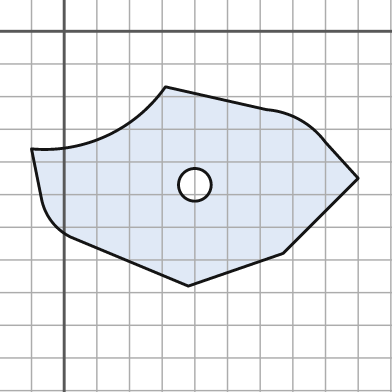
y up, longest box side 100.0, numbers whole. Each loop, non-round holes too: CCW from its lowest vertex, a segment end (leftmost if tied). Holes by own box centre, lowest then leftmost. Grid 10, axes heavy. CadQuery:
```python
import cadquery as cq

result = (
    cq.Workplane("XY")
    .moveTo(38.0, -78.0)
    .lineTo(67.0, -68.0)
    .lineTo(90.0, -45.0)
    .lineTo(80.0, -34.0)
    .threePointArc((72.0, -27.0), (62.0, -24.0))
    .lineTo(31.0, -17.0)
    .threePointArc((13.0, -32.0), (-10.0, -36.0))
    .lineTo(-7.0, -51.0)
    .threePointArc((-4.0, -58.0), (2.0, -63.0))
    .close()
    .moveTo(40.0, -47.0)
    .circle(5.0)
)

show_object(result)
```